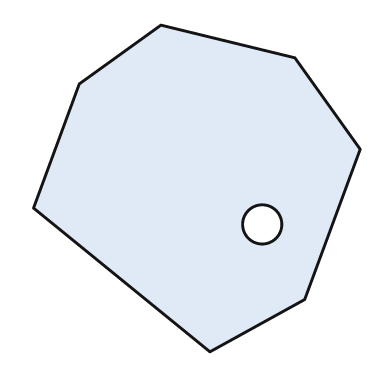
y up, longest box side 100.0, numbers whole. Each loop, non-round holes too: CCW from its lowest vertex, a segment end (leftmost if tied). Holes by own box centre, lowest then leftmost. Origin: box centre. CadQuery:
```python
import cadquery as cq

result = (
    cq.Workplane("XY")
    .moveTo(4.0, -50.0)
    .lineTo(33.0, -34.0)
    .lineTo(50.0, 12.0)
    .lineTo(30.0, 40.0)
    .lineTo(-11.0, 50.0)
    .lineTo(-36.0, 32.0)
    .lineTo(-50.0, -6.0)
    .close()
    .moveTo(20.0, -11.0)
    .circle(6.0)
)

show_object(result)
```